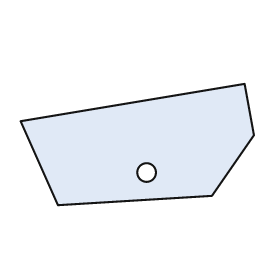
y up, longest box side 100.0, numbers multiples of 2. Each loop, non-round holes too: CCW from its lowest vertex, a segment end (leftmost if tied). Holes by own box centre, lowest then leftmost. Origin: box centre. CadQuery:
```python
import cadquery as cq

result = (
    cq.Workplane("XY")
    .moveTo(-34.0, -26.0)
    .lineTo(32.0, -22.0)
    .lineTo(50.0, 4.0)
    .lineTo(46.0, 26.0)
    .lineTo(-50.0, 10.0)
    .close()
    .moveTo(4.0, -12.0)
    .circle(4.0)
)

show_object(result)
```